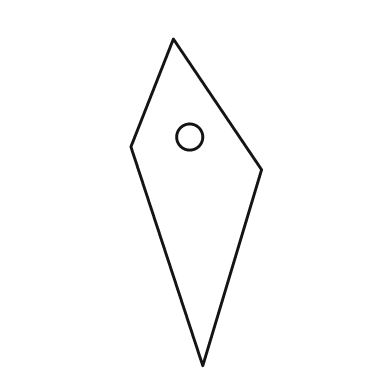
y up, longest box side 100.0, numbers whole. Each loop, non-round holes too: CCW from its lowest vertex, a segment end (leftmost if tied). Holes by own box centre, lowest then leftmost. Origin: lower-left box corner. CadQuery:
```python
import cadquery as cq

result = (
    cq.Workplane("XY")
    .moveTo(22.0, 0.0)
    .lineTo(40.0, 60.0)
    .lineTo(13.0, 100.0)
    .lineTo(0.0, 67.0)
    .close()
    .moveTo(18.0, 70.0)
    .circle(4.0)
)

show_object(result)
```